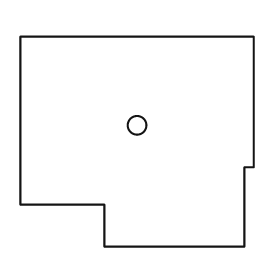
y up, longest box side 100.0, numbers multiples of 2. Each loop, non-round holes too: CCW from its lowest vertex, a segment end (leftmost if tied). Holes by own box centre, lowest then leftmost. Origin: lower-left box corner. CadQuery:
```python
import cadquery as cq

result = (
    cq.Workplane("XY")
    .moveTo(36.0, 0.0)
    .lineTo(96.0, 0.0)
    .lineTo(96.0, 34.0)
    .lineTo(100.0, 34.0)
    .lineTo(100.0, 90.0)
    .lineTo(0.0, 90.0)
    .lineTo(0.0, 18.0)
    .lineTo(36.0, 18.0)
    .close()
    .moveTo(50.0, 52.0)
    .circle(4.0)
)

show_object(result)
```